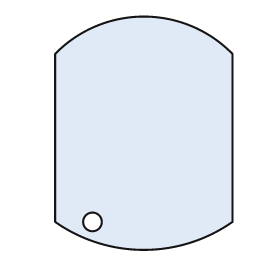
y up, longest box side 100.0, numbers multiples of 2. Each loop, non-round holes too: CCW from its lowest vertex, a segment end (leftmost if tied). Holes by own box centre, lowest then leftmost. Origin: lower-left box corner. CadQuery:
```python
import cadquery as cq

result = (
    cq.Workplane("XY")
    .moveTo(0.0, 12.0)
    .threePointArc((38.0, 0.0), (76.0, 12.0))
    .lineTo(76.0, 84.0)
    .threePointArc((38.0, 100.0), (0.0, 84.0))
    .close()
    .moveTo(16.0, 12.0)
    .circle(4.0)
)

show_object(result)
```